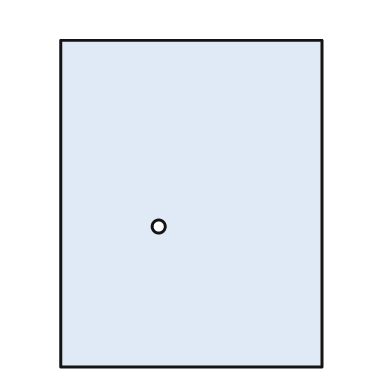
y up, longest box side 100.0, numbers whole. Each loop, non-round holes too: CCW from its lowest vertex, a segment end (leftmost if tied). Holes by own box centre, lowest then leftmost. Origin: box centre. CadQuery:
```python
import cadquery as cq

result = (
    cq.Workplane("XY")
    .moveTo(-40.0, -50.0)
    .lineTo(40.0, -50.0)
    .lineTo(40.0, 50.0)
    .lineTo(-40.0, 50.0)
    .close()
    .moveTo(-10.0, -7.0)
    .circle(2.0)
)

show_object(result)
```